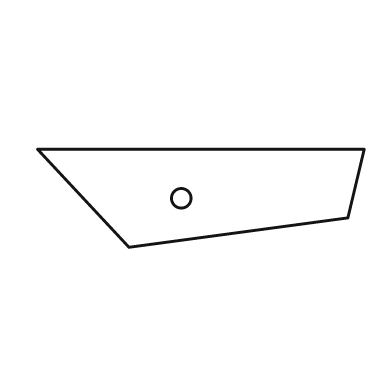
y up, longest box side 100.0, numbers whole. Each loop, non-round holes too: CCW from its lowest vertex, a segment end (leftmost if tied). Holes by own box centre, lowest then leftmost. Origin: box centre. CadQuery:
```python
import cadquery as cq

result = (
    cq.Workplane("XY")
    .moveTo(-22.0, -15.0)
    .lineTo(45.0, -6.0)
    .lineTo(50.0, 15.0)
    .lineTo(-50.0, 15.0)
    .close()
    .moveTo(-6.0, 0.0)
    .circle(3.0)
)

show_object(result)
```